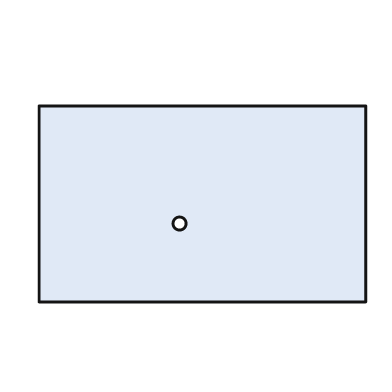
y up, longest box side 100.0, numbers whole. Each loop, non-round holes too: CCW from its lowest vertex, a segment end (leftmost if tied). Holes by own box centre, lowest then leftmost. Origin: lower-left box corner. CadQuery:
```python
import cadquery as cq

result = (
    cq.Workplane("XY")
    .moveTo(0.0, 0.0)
    .lineTo(100.0, 0.0)
    .lineTo(100.0, 60.0)
    .lineTo(0.0, 60.0)
    .close()
    .moveTo(43.0, 24.0)
    .circle(2.0)
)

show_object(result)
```